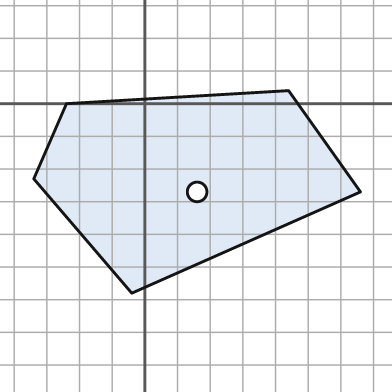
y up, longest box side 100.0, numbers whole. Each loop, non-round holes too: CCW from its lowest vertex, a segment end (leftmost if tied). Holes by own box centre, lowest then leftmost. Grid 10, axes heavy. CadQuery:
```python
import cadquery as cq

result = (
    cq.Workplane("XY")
    .moveTo(-4.0, -58.0)
    .lineTo(66.0, -27.0)
    .lineTo(44.0, 4.0)
    .lineTo(-24.0, 0.0)
    .lineTo(-34.0, -23.0)
    .close()
    .moveTo(16.0, -27.0)
    .circle(3.0)
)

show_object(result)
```